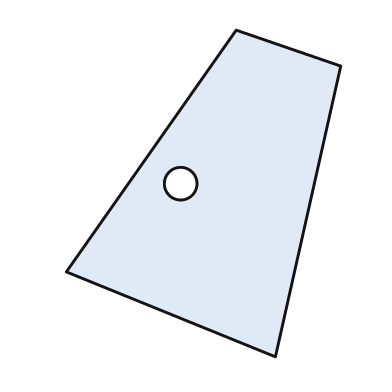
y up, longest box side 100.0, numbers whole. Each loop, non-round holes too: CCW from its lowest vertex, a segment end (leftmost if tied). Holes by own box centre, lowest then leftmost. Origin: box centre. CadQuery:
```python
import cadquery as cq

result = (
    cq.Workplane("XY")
    .moveTo(22.0, -50.0)
    .lineTo(42.0, 39.0)
    .lineTo(10.0, 50.0)
    .lineTo(-42.0, -24.0)
    .close()
    .moveTo(-7.0, 3.0)
    .circle(5.0)
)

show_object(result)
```